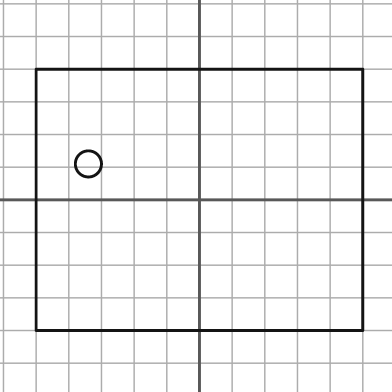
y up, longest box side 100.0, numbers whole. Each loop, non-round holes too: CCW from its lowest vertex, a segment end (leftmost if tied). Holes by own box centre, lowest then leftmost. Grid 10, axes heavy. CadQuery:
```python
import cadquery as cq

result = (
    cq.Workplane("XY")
    .moveTo(-50.0, -40.0)
    .lineTo(50.0, -40.0)
    .lineTo(50.0, 40.0)
    .lineTo(-50.0, 40.0)
    .close()
    .moveTo(-34.0, 11.0)
    .circle(4.0)
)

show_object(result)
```